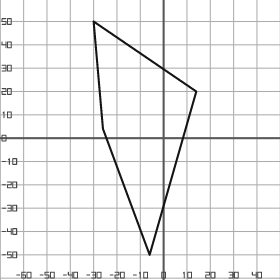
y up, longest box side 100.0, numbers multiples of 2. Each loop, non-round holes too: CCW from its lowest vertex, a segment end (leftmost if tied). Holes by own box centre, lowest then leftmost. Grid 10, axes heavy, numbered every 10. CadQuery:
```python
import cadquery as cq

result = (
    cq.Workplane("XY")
    .moveTo(-6.0, -50.0)
    .lineTo(14.0, 20.0)
    .lineTo(-30.0, 50.0)
    .lineTo(-26.0, 4.0)
    .close()
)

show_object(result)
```